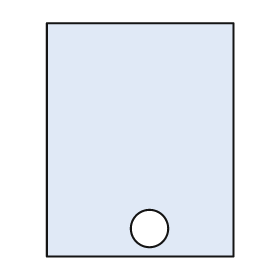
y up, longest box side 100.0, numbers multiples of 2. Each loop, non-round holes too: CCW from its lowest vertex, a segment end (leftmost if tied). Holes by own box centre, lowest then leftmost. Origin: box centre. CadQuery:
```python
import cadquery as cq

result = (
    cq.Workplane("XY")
    .moveTo(-40.0, -50.0)
    .lineTo(40.0, -50.0)
    .lineTo(40.0, 50.0)
    .lineTo(-40.0, 50.0)
    .close()
    .moveTo(4.0, -38.0)
    .circle(8.0)
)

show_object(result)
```